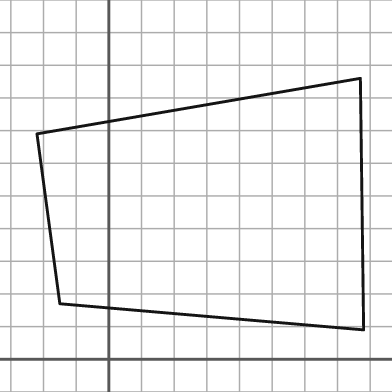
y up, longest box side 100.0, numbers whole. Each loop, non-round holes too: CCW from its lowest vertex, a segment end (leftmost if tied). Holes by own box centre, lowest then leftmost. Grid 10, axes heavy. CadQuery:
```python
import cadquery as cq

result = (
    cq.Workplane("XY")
    .moveTo(78.0, 9.0)
    .lineTo(77.0, 86.0)
    .lineTo(-22.0, 69.0)
    .lineTo(-15.0, 17.0)
    .close()
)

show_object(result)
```